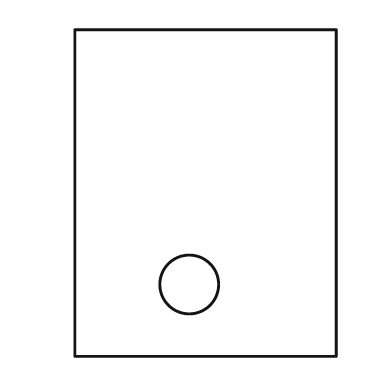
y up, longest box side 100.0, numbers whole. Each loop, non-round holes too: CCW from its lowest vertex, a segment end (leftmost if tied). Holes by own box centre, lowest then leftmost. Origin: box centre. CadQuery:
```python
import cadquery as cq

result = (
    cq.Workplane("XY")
    .moveTo(-40.0, -50.0)
    .lineTo(40.0, -50.0)
    .lineTo(40.0, 50.0)
    .lineTo(-40.0, 50.0)
    .close()
    .moveTo(-5.0, -28.0)
    .circle(9.0)
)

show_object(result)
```